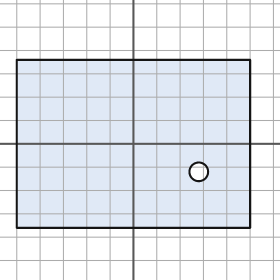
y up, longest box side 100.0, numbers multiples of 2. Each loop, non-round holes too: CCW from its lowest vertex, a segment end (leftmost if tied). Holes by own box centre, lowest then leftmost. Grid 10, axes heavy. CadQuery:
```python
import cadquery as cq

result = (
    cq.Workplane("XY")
    .moveTo(-50.0, -36.0)
    .lineTo(50.0, -36.0)
    .lineTo(50.0, 36.0)
    .lineTo(-50.0, 36.0)
    .close()
    .moveTo(28.0, -12.0)
    .circle(4.0)
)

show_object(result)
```